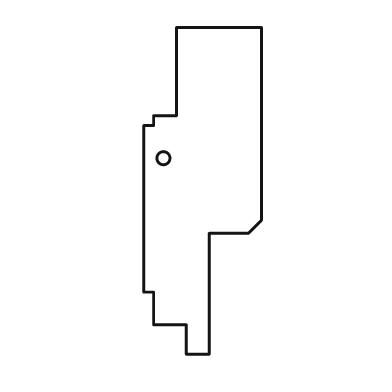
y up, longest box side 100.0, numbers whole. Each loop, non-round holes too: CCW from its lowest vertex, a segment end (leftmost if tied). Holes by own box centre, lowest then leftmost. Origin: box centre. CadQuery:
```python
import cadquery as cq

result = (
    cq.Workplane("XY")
    .moveTo(-5.0, -50.0)
    .lineTo(2.0, -50.0)
    .lineTo(2.0, -13.0)
    .lineTo(14.0, -13.0)
    .lineTo(18.0, -9.0)
    .lineTo(18.0, 50.0)
    .lineTo(-8.0, 50.0)
    .lineTo(-8.0, 23.0)
    .lineTo(-15.0, 23.0)
    .lineTo(-15.0, 20.0)
    .lineTo(-18.0, 20.0)
    .lineTo(-18.0, -31.0)
    .lineTo(-15.0, -31.0)
    .lineTo(-15.0, -41.0)
    .lineTo(-5.0, -41.0)
    .close()
    .moveTo(-12.0, 10.0)
    .circle(2.0)
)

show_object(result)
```